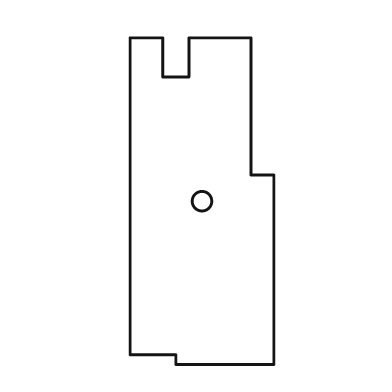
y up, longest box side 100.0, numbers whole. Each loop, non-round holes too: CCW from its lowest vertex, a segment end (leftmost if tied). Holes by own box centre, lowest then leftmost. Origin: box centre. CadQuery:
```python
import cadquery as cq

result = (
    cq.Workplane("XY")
    .moveTo(-8.0, -50.0)
    .lineTo(22.0, -50.0)
    .lineTo(22.0, 8.0)
    .lineTo(15.0, 8.0)
    .lineTo(15.0, 50.0)
    .lineTo(-4.0, 50.0)
    .lineTo(-4.0, 38.0)
    .lineTo(-12.0, 38.0)
    .lineTo(-12.0, 50.0)
    .lineTo(-22.0, 50.0)
    .lineTo(-22.0, -47.0)
    .lineTo(-8.0, -47.0)
    .close()
    .moveTo(0.0, 0.0)
    .circle(3.0)
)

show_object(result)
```